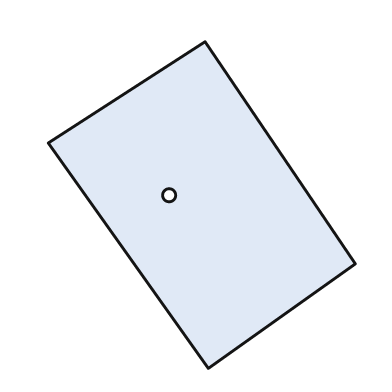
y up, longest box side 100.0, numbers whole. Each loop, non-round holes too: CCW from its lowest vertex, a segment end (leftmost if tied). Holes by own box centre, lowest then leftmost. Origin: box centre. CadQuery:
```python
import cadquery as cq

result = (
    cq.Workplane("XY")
    .moveTo(2.0, -50.0)
    .lineTo(47.0, -18.0)
    .lineTo(1.0, 50.0)
    .lineTo(-47.0, 19.0)
    .close()
    .moveTo(-10.0, 3.0)
    .circle(2.0)
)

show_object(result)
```